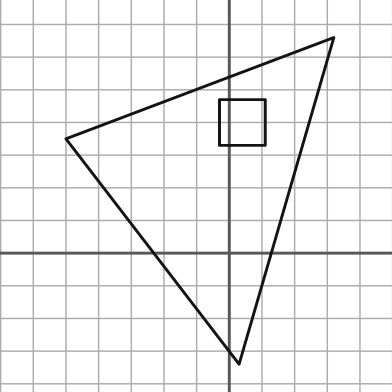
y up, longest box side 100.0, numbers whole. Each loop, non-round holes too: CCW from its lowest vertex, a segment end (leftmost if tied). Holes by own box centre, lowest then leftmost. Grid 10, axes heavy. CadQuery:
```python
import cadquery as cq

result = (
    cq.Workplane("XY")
    .moveTo(3.0, -34.0)
    .lineTo(32.0, 66.0)
    .lineTo(-50.0, 35.0)
    .close()
    .moveTo(-3.0, 33.0)
    .lineTo(11.0, 33.0)
    .lineTo(11.0, 47.0)
    .lineTo(-3.0, 47.0)
    .close()
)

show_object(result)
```